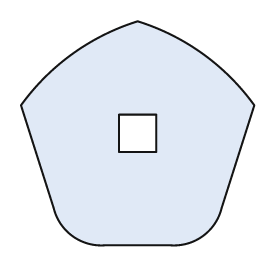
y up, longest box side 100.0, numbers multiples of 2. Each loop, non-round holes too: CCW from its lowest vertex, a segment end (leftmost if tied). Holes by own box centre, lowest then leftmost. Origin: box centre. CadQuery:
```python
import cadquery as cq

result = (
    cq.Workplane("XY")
    .moveTo(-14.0, -48.0)
    .lineTo(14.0, -48.0)
    .threePointArc((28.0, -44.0), (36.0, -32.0))
    .lineTo(50.0, 12.0)
    .threePointArc((28.0, 34.0), (0.0, 48.0))
    .threePointArc((-28.0, 34.0), (-50.0, 12.0))
    .lineTo(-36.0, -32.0)
    .threePointArc((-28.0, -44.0), (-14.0, -48.0))
    .close()
    .moveTo(-8.0, -8.0)
    .lineTo(8.0, -8.0)
    .lineTo(8.0, 8.0)
    .lineTo(-8.0, 8.0)
    .close()
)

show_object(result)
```